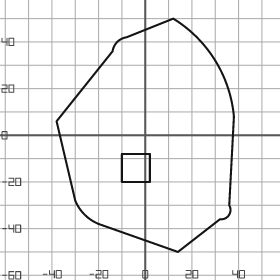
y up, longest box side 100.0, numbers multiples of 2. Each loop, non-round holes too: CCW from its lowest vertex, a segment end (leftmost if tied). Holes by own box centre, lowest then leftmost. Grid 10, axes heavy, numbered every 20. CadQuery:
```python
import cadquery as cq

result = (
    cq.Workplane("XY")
    .moveTo(14.0, -50.0)
    .lineTo(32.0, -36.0)
    .threePointArc((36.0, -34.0), (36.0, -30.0))
    .lineTo(38.0, 8.0)
    .threePointArc((30.0, 32.0), (12.0, 50.0))
    .lineTo(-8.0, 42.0)
    .threePointArc((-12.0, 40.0), (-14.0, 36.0))
    .lineTo(-38.0, 6.0)
    .lineTo(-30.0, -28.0)
    .threePointArc((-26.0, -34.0), (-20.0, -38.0))
    .close()
    .moveTo(-10.0, -20.0)
    .lineTo(2.0, -20.0)
    .lineTo(2.0, -8.0)
    .lineTo(-10.0, -8.0)
    .close()
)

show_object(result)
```